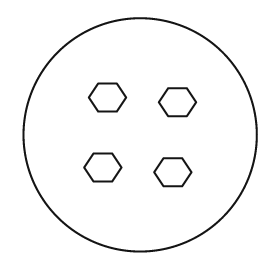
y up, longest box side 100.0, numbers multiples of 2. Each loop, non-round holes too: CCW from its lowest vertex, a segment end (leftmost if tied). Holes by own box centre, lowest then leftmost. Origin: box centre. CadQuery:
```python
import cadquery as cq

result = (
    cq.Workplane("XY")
    .moveTo(0.0, 0.0)
    .circle(50.0)
    .moveTo(10.0, -22.0)
    .lineTo(18.0, -22.0)
    .lineTo(22.0, -16.0)
    .lineTo(18.0, -10.0)
    .lineTo(10.0, -10.0)
    .lineTo(6.0, -16.0)
    .close()
    .moveTo(-20.0, -20.0)
    .lineTo(-12.0, -20.0)
    .lineTo(-8.0, -14.0)
    .lineTo(-12.0, -8.0)
    .lineTo(-20.0, -8.0)
    .lineTo(-24.0, -14.0)
    .close()
    .moveTo(12.0, 8.0)
    .lineTo(20.0, 8.0)
    .lineTo(24.0, 14.0)
    .lineTo(20.0, 20.0)
    .lineTo(12.0, 20.0)
    .lineTo(8.0, 14.0)
    .close()
    .moveTo(-18.0, 10.0)
    .lineTo(-10.0, 10.0)
    .lineTo(-6.0, 16.0)
    .lineTo(-10.0, 22.0)
    .lineTo(-18.0, 22.0)
    .lineTo(-22.0, 16.0)
    .close()
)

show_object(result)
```